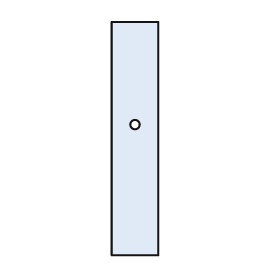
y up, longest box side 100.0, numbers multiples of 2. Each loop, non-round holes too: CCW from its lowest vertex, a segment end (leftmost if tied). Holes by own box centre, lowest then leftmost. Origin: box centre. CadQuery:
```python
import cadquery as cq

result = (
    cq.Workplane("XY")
    .moveTo(-10.0, -50.0)
    .lineTo(10.0, -50.0)
    .lineTo(10.0, 50.0)
    .lineTo(-10.0, 50.0)
    .close()
    .moveTo(0.0, 6.0)
    .circle(2.0)
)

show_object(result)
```